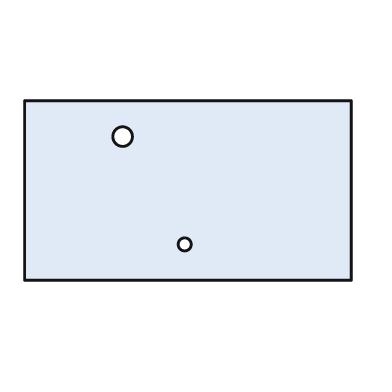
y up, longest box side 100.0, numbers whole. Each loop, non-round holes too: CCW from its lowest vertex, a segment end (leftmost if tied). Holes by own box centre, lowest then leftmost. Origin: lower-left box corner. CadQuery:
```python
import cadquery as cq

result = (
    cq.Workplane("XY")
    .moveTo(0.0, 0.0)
    .lineTo(100.0, 0.0)
    .lineTo(100.0, 55.0)
    .lineTo(0.0, 55.0)
    .close()
    .moveTo(49.0, 11.0)
    .circle(2.0)
    .moveTo(30.0, 44.0)
    .circle(3.0)
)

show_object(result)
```